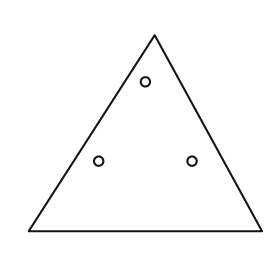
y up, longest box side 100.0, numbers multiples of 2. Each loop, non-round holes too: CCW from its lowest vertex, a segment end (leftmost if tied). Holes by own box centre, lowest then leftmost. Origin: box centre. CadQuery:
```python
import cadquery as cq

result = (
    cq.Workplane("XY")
    .moveTo(-50.0, -42.0)
    .lineTo(50.0, -42.0)
    .lineTo(4.0, 42.0)
    .close()
    .moveTo(-20.0, -12.0)
    .circle(2.0)
    .moveTo(20.0, -12.0)
    .circle(2.0)
    .moveTo(0.0, 22.0)
    .circle(2.0)
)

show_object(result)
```